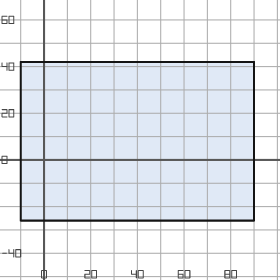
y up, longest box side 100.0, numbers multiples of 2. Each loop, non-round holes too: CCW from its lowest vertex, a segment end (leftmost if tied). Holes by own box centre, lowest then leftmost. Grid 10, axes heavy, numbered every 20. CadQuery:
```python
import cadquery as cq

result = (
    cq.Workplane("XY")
    .moveTo(-10.0, -26.0)
    .lineTo(90.0, -26.0)
    .lineTo(90.0, 42.0)
    .lineTo(-10.0, 42.0)
    .close()
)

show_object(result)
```